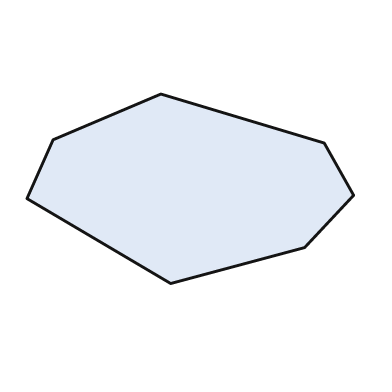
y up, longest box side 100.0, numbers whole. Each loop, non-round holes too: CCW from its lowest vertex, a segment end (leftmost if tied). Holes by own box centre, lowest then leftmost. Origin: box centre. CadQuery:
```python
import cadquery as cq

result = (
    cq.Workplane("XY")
    .moveTo(-6.0, -29.0)
    .lineTo(35.0, -18.0)
    .lineTo(50.0, -2.0)
    .lineTo(41.0, 14.0)
    .lineTo(-9.0, 29.0)
    .lineTo(-42.0, 15.0)
    .lineTo(-50.0, -3.0)
    .close()
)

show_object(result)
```